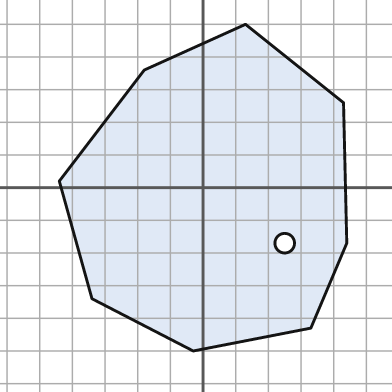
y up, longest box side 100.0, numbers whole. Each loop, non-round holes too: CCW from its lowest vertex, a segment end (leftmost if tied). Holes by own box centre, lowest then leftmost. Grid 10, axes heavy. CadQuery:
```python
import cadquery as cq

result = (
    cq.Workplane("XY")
    .moveTo(-3.0, -50.0)
    .lineTo(33.0, -43.0)
    .lineTo(44.0, -17.0)
    .lineTo(43.0, 26.0)
    .lineTo(13.0, 50.0)
    .lineTo(-18.0, 36.0)
    .lineTo(-44.0, 2.0)
    .lineTo(-34.0, -34.0)
    .close()
    .moveTo(25.0, -17.0)
    .circle(3.0)
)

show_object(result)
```